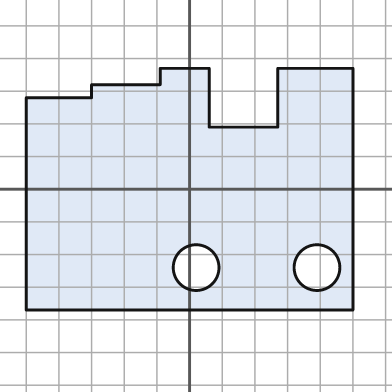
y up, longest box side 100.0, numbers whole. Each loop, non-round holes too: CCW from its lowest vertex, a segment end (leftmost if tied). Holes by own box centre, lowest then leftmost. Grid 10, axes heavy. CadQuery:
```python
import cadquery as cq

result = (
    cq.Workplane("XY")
    .moveTo(-50.0, -37.0)
    .lineTo(50.0, -37.0)
    .lineTo(50.0, 37.0)
    .lineTo(27.0, 37.0)
    .lineTo(27.0, 19.0)
    .lineTo(6.0, 19.0)
    .lineTo(6.0, 37.0)
    .lineTo(-9.0, 37.0)
    .lineTo(-9.0, 32.0)
    .lineTo(-30.0, 32.0)
    .lineTo(-30.0, 28.0)
    .lineTo(-50.0, 28.0)
    .close()
    .moveTo(2.0, -24.0)
    .circle(7.0)
    .moveTo(39.0, -24.0)
    .circle(7.0)
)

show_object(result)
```